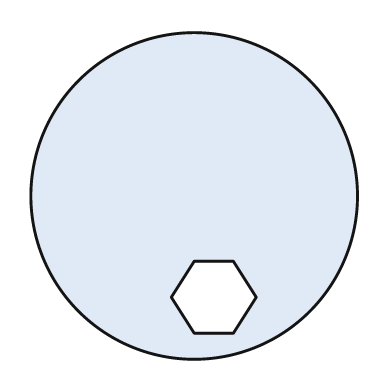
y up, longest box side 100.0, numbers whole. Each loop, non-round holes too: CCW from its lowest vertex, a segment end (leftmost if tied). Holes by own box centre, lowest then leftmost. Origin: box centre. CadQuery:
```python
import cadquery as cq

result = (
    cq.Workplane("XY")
    .moveTo(0.0, 0.0)
    .circle(50.0)
    .moveTo(0.0, -42.0)
    .lineTo(12.0, -42.0)
    .lineTo(19.0, -31.0)
    .lineTo(12.0, -20.0)
    .lineTo(0.0, -20.0)
    .lineTo(-7.0, -31.0)
    .close()
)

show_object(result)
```